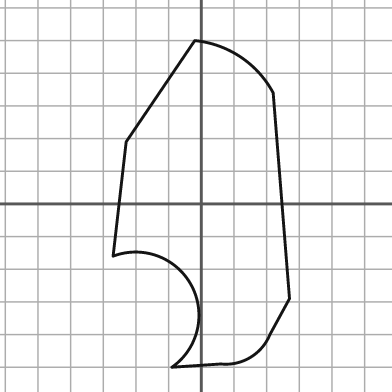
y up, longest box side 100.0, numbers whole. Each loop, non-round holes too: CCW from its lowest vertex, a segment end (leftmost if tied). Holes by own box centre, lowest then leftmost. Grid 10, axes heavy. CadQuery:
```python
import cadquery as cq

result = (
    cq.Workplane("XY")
    .moveTo(-9.0, -50.0)
    .lineTo(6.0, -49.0)
    .threePointArc((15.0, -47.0), (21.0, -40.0))
    .lineTo(27.0, -29.0)
    .lineTo(22.0, 34.0)
    .threePointArc((12.0, 45.0), (-2.0, 50.0))
    .lineTo(-23.0, 19.0)
    .lineTo(-27.0, -16.0)
    .threePointArc((-3.0, -25.0), (-9.0, -50.0))
    .close()
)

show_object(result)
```